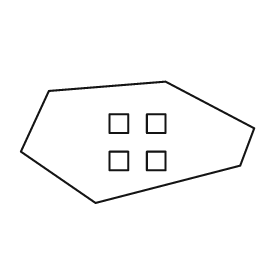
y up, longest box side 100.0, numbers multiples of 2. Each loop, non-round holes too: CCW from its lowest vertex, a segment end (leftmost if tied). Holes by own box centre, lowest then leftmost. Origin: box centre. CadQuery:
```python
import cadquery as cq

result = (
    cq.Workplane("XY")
    .moveTo(-18.0, -26.0)
    .lineTo(44.0, -10.0)
    .lineTo(50.0, 6.0)
    .lineTo(12.0, 26.0)
    .lineTo(-38.0, 22.0)
    .lineTo(-50.0, -4.0)
    .close()
    .moveTo(-12.0, -12.0)
    .lineTo(-4.0, -12.0)
    .lineTo(-4.0, -4.0)
    .lineTo(-12.0, -4.0)
    .close()
    .moveTo(4.0, -12.0)
    .lineTo(12.0, -12.0)
    .lineTo(12.0, -4.0)
    .lineTo(4.0, -4.0)
    .close()
    .moveTo(-12.0, 4.0)
    .lineTo(-4.0, 4.0)
    .lineTo(-4.0, 12.0)
    .lineTo(-12.0, 12.0)
    .close()
    .moveTo(4.0, 4.0)
    .lineTo(12.0, 4.0)
    .lineTo(12.0, 12.0)
    .lineTo(4.0, 12.0)
    .close()
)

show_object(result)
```